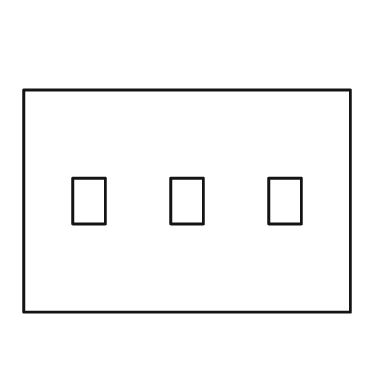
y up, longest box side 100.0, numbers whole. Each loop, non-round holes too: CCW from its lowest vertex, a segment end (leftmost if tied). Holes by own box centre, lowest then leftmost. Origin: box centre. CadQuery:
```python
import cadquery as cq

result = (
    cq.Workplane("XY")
    .moveTo(-50.0, -34.0)
    .lineTo(50.0, -34.0)
    .lineTo(50.0, 34.0)
    .lineTo(-50.0, 34.0)
    .close()
    .moveTo(-35.0, -7.0)
    .lineTo(-25.0, -7.0)
    .lineTo(-25.0, 7.0)
    .lineTo(-35.0, 7.0)
    .close()
    .moveTo(-5.0, -7.0)
    .lineTo(5.0, -7.0)
    .lineTo(5.0, 7.0)
    .lineTo(-5.0, 7.0)
    .close()
    .moveTo(25.0, -7.0)
    .lineTo(35.0, -7.0)
    .lineTo(35.0, 7.0)
    .lineTo(25.0, 7.0)
    .close()
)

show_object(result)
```